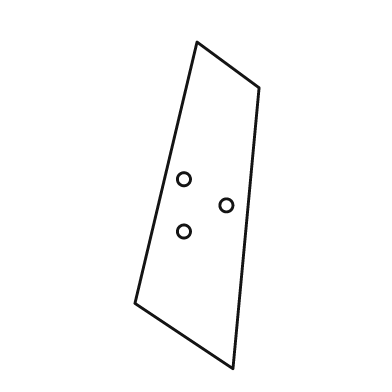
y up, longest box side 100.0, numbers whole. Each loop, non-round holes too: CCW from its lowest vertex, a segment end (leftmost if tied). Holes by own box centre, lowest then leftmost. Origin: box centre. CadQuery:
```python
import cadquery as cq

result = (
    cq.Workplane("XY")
    .moveTo(11.0, -50.0)
    .lineTo(19.0, 36.0)
    .lineTo(0.0, 50.0)
    .lineTo(-19.0, -30.0)
    .close()
    .moveTo(-4.0, -8.0)
    .circle(2.0)
    .moveTo(9.0, 0.0)
    .circle(2.0)
    .moveTo(-4.0, 8.0)
    .circle(2.0)
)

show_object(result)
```